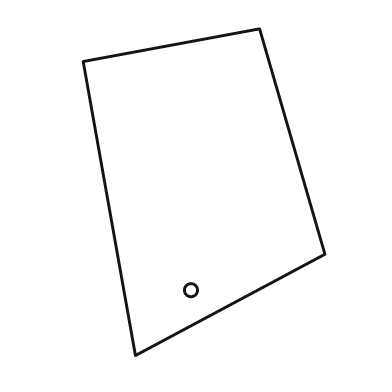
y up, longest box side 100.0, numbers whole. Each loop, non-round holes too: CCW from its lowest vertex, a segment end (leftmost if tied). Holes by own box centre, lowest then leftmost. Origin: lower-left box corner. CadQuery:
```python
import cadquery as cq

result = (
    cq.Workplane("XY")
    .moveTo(16.0, 0.0)
    .lineTo(74.0, 31.0)
    .lineTo(54.0, 100.0)
    .lineTo(0.0, 90.0)
    .close()
    .moveTo(33.0, 20.0)
    .circle(2.0)
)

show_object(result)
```